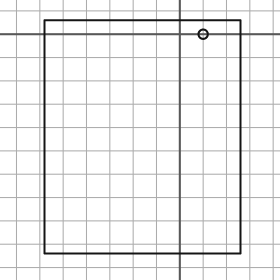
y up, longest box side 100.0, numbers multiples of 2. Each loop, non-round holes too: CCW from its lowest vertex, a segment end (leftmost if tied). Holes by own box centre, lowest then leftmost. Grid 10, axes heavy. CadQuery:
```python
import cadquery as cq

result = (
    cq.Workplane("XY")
    .moveTo(-58.0, -94.0)
    .lineTo(26.0, -94.0)
    .lineTo(26.0, 6.0)
    .lineTo(-58.0, 6.0)
    .close()
    .moveTo(10.0, 0.0)
    .circle(2.0)
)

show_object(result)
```